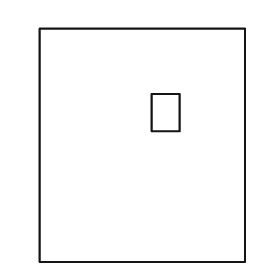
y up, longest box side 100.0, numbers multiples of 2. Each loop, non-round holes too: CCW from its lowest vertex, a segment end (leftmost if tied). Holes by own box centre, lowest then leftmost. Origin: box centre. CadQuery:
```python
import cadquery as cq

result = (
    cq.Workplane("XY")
    .moveTo(-44.0, -50.0)
    .lineTo(44.0, -50.0)
    .lineTo(44.0, 50.0)
    .lineTo(-44.0, 50.0)
    .close()
    .moveTo(4.0, 6.0)
    .lineTo(16.0, 6.0)
    .lineTo(16.0, 22.0)
    .lineTo(4.0, 22.0)
    .close()
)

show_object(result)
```